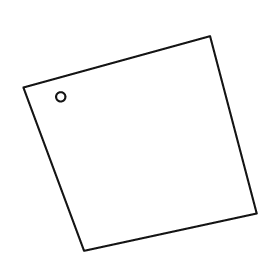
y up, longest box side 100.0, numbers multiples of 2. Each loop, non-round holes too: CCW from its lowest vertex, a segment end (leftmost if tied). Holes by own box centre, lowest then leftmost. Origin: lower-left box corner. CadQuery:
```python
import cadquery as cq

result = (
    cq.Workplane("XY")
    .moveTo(26.0, 0.0)
    .lineTo(100.0, 16.0)
    .lineTo(80.0, 92.0)
    .lineTo(0.0, 70.0)
    .close()
    .moveTo(16.0, 66.0)
    .circle(2.0)
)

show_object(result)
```